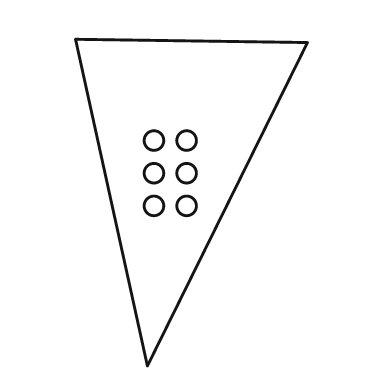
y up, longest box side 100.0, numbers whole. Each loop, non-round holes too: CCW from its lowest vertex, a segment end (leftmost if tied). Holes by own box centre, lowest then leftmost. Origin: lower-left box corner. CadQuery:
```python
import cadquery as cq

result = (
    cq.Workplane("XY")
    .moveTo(22.0, 0.0)
    .lineTo(71.0, 99.0)
    .lineTo(0.0, 100.0)
    .close()
    .moveTo(24.0, 49.0)
    .circle(3.0)
    .moveTo(34.0, 49.0)
    .circle(3.0)
    .moveTo(24.0, 59.0)
    .circle(3.0)
    .moveTo(34.0, 59.0)
    .circle(3.0)
    .moveTo(24.0, 69.0)
    .circle(3.0)
    .moveTo(34.0, 69.0)
    .circle(3.0)
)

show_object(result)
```